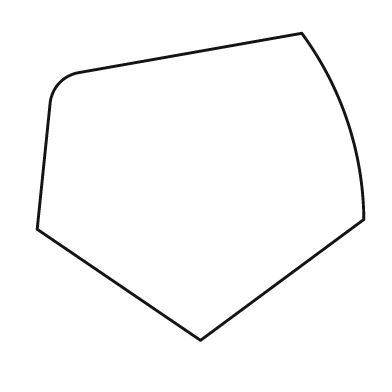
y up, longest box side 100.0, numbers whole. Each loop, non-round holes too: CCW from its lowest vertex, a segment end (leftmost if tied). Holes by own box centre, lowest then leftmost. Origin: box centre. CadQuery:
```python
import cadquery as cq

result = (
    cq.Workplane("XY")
    .moveTo(0.0, -47.0)
    .lineTo(50.0, -10.0)
    .threePointArc((45.0, 20.0), (31.0, 47.0))
    .lineTo(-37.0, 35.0)
    .threePointArc((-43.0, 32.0), (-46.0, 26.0))
    .lineTo(-50.0, -13.0)
    .close()
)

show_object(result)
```